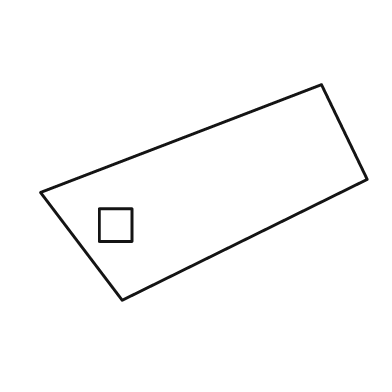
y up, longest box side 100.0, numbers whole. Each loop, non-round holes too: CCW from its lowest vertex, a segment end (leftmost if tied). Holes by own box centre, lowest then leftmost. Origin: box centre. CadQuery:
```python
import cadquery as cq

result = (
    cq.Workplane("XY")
    .moveTo(-25.0, -33.0)
    .lineTo(50.0, 4.0)
    .lineTo(36.0, 33.0)
    .lineTo(-50.0, 0.0)
    .close()
    .moveTo(-32.0, -15.0)
    .lineTo(-22.0, -15.0)
    .lineTo(-22.0, -5.0)
    .lineTo(-32.0, -5.0)
    .close()
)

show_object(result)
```